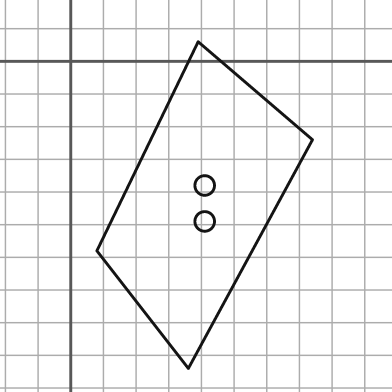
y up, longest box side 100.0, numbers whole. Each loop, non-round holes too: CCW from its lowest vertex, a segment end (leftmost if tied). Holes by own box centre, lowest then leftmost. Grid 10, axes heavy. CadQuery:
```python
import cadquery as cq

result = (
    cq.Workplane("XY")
    .moveTo(36.0, -94.0)
    .lineTo(74.0, -24.0)
    .lineTo(39.0, 6.0)
    .lineTo(8.0, -58.0)
    .close()
    .moveTo(41.0, -49.0)
    .circle(3.0)
    .moveTo(41.0, -38.0)
    .circle(3.0)
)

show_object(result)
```